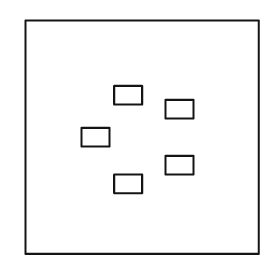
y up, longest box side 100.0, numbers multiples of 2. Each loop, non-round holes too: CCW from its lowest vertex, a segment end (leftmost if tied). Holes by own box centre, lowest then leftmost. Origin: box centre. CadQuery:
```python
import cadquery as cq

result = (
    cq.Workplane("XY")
    .moveTo(-50.0, -50.0)
    .lineTo(50.0, -50.0)
    .lineTo(50.0, 50.0)
    .lineTo(-50.0, 50.0)
    .close()
    .moveTo(-12.0, -24.0)
    .lineTo(0.0, -24.0)
    .lineTo(0.0, -16.0)
    .lineTo(-12.0, -16.0)
    .close()
    .moveTo(10.0, -16.0)
    .lineTo(22.0, -16.0)
    .lineTo(22.0, -8.0)
    .lineTo(10.0, -8.0)
    .close()
    .moveTo(-26.0, -4.0)
    .lineTo(-14.0, -4.0)
    .lineTo(-14.0, 4.0)
    .lineTo(-26.0, 4.0)
    .close()
    .moveTo(10.0, 8.0)
    .lineTo(22.0, 8.0)
    .lineTo(22.0, 16.0)
    .lineTo(10.0, 16.0)
    .close()
    .moveTo(-12.0, 14.0)
    .lineTo(0.0, 14.0)
    .lineTo(0.0, 22.0)
    .lineTo(-12.0, 22.0)
    .close()
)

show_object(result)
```